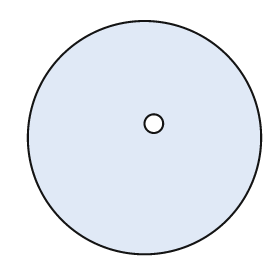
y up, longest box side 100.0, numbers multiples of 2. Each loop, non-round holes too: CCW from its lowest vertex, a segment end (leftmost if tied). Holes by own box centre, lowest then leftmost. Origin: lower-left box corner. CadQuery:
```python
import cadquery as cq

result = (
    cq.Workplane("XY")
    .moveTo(50.0, 50.0)
    .circle(50.0)
    .moveTo(54.0, 56.0)
    .circle(4.0)
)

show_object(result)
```